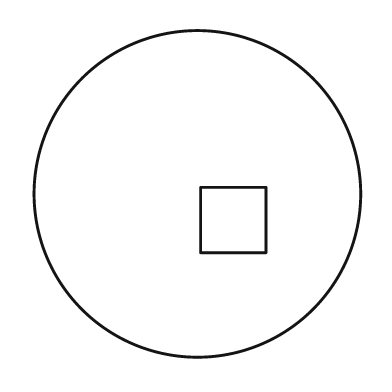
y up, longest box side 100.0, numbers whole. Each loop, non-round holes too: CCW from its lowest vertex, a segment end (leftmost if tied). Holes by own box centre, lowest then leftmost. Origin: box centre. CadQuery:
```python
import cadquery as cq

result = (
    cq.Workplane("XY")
    .moveTo(0.0, 0.0)
    .circle(50.0)
    .moveTo(1.0, -18.0)
    .lineTo(21.0, -18.0)
    .lineTo(21.0, 2.0)
    .lineTo(1.0, 2.0)
    .close()
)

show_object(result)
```